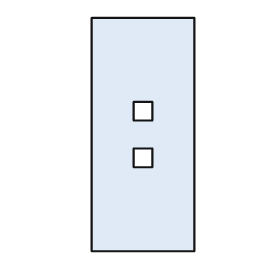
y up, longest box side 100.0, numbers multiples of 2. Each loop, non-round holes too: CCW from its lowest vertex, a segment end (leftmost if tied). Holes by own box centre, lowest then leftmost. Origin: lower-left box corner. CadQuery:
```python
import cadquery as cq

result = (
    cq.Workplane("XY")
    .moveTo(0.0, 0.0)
    .lineTo(44.0, 0.0)
    .lineTo(44.0, 100.0)
    .lineTo(0.0, 100.0)
    .close()
    .moveTo(18.0, 36.0)
    .lineTo(26.0, 36.0)
    .lineTo(26.0, 44.0)
    .lineTo(18.0, 44.0)
    .close()
    .moveTo(18.0, 56.0)
    .lineTo(26.0, 56.0)
    .lineTo(26.0, 64.0)
    .lineTo(18.0, 64.0)
    .close()
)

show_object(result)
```